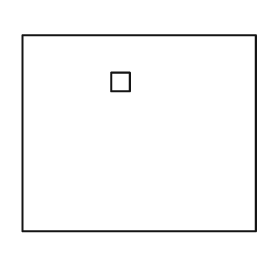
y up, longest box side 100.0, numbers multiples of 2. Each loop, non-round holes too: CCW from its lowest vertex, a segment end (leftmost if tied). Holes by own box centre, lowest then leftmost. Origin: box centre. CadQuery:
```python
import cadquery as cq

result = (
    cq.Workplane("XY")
    .moveTo(-50.0, -42.0)
    .lineTo(50.0, -42.0)
    .lineTo(50.0, 42.0)
    .lineTo(-50.0, 42.0)
    .close()
    .moveTo(-12.0, 18.0)
    .lineTo(-4.0, 18.0)
    .lineTo(-4.0, 26.0)
    .lineTo(-12.0, 26.0)
    .close()
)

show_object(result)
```